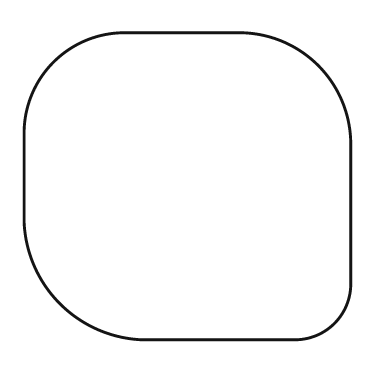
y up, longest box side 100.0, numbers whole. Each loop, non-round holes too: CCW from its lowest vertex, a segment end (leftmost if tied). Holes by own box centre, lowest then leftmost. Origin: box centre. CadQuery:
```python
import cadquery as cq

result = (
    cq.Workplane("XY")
    .moveTo(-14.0, -47.0)
    .lineTo(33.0, -47.0)
    .threePointArc((45.0, -42.0), (50.0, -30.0))
    .lineTo(50.0, 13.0)
    .threePointArc((40.0, 37.0), (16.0, 47.0))
    .lineTo(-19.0, 47.0)
    .threePointArc((-41.0, 38.0), (-50.0, 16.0))
    .lineTo(-50.0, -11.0)
    .threePointArc((-39.0, -36.0), (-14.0, -47.0))
    .close()
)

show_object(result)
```